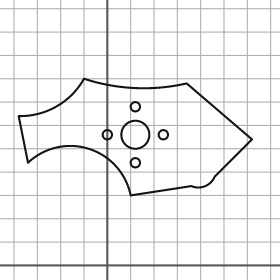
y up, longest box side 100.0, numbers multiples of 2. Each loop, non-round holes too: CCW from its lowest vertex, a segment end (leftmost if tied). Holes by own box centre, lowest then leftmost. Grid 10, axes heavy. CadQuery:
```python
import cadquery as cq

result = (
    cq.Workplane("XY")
    .moveTo(10.0, 30.0)
    .lineTo(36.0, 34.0)
    .threePointArc((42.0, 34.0), (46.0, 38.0))
    .lineTo(62.0, 54.0)
    .lineTo(34.0, 78.0)
    .threePointArc((12.0, 76.0), (-10.0, 80.0))
    .threePointArc((-22.0, 68.0), (-38.0, 64.0))
    .lineTo(-34.0, 44.0)
    .threePointArc((-8.0, 50.0), (10.0, 30.0))
    .close()
    .moveTo(12.0, 44.0)
    .circle(2.0)
    .moveTo(0.0, 56.0)
    .circle(2.0)
    .moveTo(12.0, 56.0)
    .circle(6.0)
    .moveTo(24.0, 56.0)
    .circle(2.0)
    .moveTo(12.0, 68.0)
    .circle(2.0)
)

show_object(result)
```